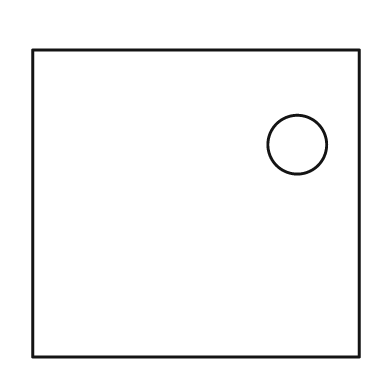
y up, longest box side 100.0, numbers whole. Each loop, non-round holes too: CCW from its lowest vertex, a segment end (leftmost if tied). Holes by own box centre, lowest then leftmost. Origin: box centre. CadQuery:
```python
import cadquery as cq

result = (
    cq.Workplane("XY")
    .moveTo(-50.0, -47.0)
    .lineTo(50.0, -47.0)
    .lineTo(50.0, 47.0)
    .lineTo(-50.0, 47.0)
    .close()
    .moveTo(31.0, 18.0)
    .circle(9.0)
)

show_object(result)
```